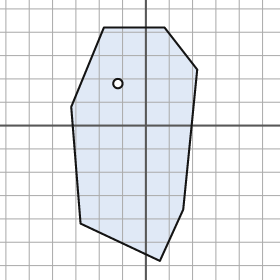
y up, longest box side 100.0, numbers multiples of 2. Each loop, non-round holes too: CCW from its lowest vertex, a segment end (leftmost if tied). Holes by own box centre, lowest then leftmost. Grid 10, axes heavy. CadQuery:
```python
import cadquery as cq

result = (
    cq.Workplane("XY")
    .moveTo(6.0, -58.0)
    .lineTo(16.0, -36.0)
    .lineTo(22.0, 24.0)
    .lineTo(8.0, 42.0)
    .lineTo(-18.0, 42.0)
    .lineTo(-32.0, 8.0)
    .lineTo(-28.0, -42.0)
    .close()
    .moveTo(-12.0, 18.0)
    .circle(2.0)
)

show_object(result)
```